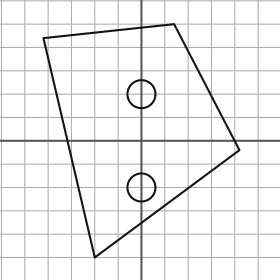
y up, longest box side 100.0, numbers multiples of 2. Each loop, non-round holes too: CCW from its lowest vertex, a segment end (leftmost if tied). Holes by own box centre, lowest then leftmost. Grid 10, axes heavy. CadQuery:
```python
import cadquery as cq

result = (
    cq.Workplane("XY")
    .moveTo(-20.0, -50.0)
    .lineTo(42.0, -4.0)
    .lineTo(14.0, 50.0)
    .lineTo(-42.0, 44.0)
    .close()
    .moveTo(0.0, -20.0)
    .circle(6.0)
    .moveTo(0.0, 20.0)
    .circle(6.0)
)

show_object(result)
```